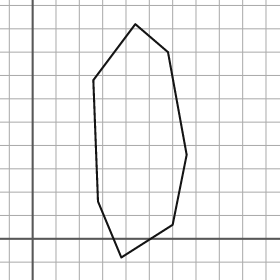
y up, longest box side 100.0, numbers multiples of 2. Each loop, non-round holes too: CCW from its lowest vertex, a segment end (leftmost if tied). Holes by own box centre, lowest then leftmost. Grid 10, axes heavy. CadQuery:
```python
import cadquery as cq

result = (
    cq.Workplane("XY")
    .moveTo(38.0, -8.0)
    .lineTo(60.0, 6.0)
    .lineTo(66.0, 36.0)
    .lineTo(58.0, 80.0)
    .lineTo(44.0, 92.0)
    .lineTo(26.0, 68.0)
    .lineTo(28.0, 16.0)
    .close()
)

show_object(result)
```